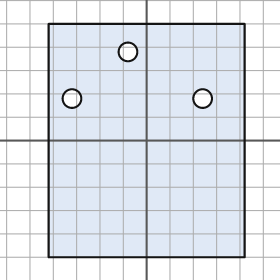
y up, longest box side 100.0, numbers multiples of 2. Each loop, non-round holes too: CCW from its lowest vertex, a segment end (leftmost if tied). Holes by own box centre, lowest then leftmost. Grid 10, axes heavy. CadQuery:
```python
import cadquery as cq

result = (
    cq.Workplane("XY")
    .moveTo(-42.0, -50.0)
    .lineTo(42.0, -50.0)
    .lineTo(42.0, 50.0)
    .lineTo(-42.0, 50.0)
    .close()
    .moveTo(-32.0, 18.0)
    .circle(4.0)
    .moveTo(24.0, 18.0)
    .circle(4.0)
    .moveTo(-8.0, 38.0)
    .circle(4.0)
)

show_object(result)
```